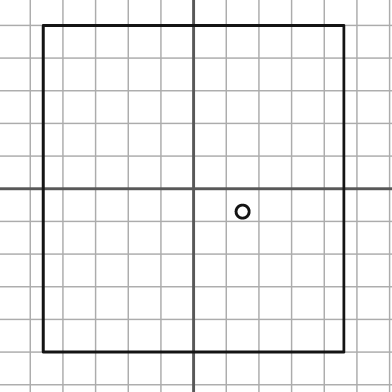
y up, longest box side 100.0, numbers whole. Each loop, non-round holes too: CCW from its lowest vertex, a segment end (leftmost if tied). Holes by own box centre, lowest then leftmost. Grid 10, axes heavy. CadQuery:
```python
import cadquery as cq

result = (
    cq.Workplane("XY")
    .moveTo(-46.0, -50.0)
    .lineTo(46.0, -50.0)
    .lineTo(46.0, 50.0)
    .lineTo(-46.0, 50.0)
    .close()
    .moveTo(15.0, -7.0)
    .circle(2.0)
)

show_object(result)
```